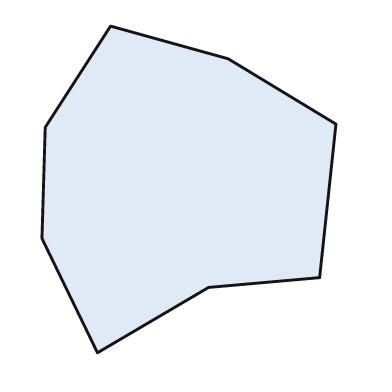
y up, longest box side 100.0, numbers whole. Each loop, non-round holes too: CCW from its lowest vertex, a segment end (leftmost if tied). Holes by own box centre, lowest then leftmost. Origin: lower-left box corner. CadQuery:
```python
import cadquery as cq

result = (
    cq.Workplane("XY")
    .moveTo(17.0, 0.0)
    .lineTo(51.0, 20.0)
    .lineTo(85.0, 23.0)
    .lineTo(90.0, 70.0)
    .lineTo(57.0, 90.0)
    .lineTo(21.0, 100.0)
    .lineTo(1.0, 69.0)
    .lineTo(0.0, 35.0)
    .close()
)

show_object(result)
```